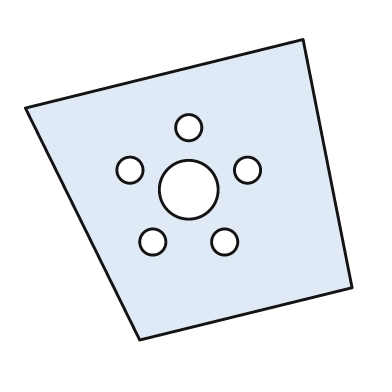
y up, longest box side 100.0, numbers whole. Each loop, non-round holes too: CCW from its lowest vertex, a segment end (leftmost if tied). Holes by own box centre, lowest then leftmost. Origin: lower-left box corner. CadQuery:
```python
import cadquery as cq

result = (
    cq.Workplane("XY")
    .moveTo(35.0, 0.0)
    .lineTo(100.0, 16.0)
    .lineTo(85.0, 92.0)
    .lineTo(0.0, 71.0)
    .close()
    .moveTo(39.0, 30.0)
    .circle(4.0)
    .moveTo(61.0, 30.0)
    .circle(4.0)
    .moveTo(50.0, 46.0)
    .circle(9.0)
    .moveTo(32.0, 52.0)
    .circle(4.0)
    .moveTo(68.0, 52.0)
    .circle(4.0)
    .moveTo(50.0, 65.0)
    .circle(4.0)
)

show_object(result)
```